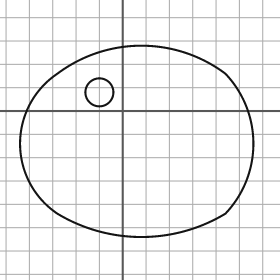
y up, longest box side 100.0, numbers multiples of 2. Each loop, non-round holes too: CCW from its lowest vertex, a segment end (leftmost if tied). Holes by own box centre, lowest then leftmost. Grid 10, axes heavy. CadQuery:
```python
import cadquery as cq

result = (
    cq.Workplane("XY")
    .moveTo(-28.0, -44.0)
    .threePointArc((8.0, -54.0), (44.0, -44.0))
    .threePointArc((56.0, -14.0), (44.0, 16.0))
    .threePointArc((8.0, 28.0), (-28.0, 16.0))
    .threePointArc((-44.0, -14.0), (-28.0, -44.0))
    .close()
    .moveTo(-10.0, 8.0)
    .circle(6.0)
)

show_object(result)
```